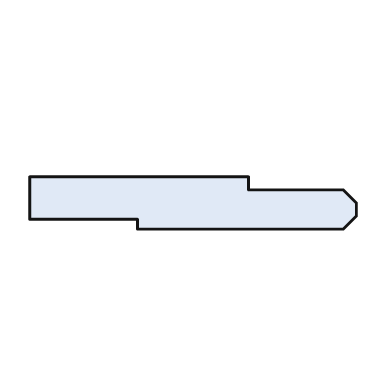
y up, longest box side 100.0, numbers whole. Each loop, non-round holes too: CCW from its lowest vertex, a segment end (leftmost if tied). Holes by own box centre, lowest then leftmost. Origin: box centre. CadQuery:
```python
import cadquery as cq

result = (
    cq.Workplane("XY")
    .moveTo(-17.0, -8.0)
    .lineTo(46.0, -8.0)
    .lineTo(50.0, -4.0)
    .lineTo(50.0, 0.0)
    .lineTo(46.0, 4.0)
    .lineTo(17.0, 4.0)
    .lineTo(17.0, 8.0)
    .lineTo(-50.0, 8.0)
    .lineTo(-50.0, -5.0)
    .lineTo(-17.0, -5.0)
    .close()
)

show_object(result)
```